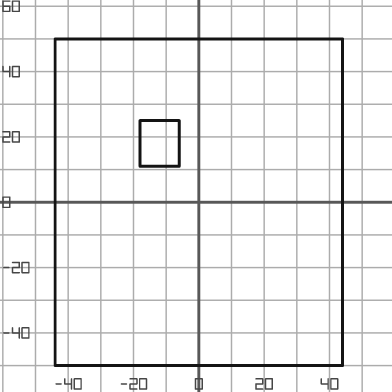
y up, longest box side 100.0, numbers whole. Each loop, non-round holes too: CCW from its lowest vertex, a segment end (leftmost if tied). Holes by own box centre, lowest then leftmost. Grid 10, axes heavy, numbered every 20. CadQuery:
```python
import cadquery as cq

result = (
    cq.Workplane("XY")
    .moveTo(-44.0, -50.0)
    .lineTo(44.0, -50.0)
    .lineTo(44.0, 50.0)
    .lineTo(-44.0, 50.0)
    .close()
    .moveTo(-18.0, 11.0)
    .lineTo(-6.0, 11.0)
    .lineTo(-6.0, 25.0)
    .lineTo(-18.0, 25.0)
    .close()
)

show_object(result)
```